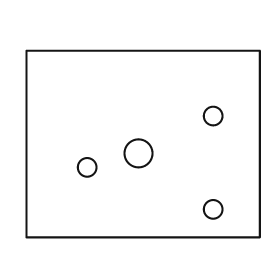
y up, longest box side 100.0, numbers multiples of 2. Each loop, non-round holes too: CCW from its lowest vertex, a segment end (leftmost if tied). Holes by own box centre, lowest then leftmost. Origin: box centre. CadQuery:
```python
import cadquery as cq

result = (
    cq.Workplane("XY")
    .moveTo(-50.0, -40.0)
    .lineTo(50.0, -40.0)
    .lineTo(50.0, 40.0)
    .lineTo(-50.0, 40.0)
    .close()
    .moveTo(30.0, -28.0)
    .circle(4.0)
    .moveTo(-24.0, -10.0)
    .circle(4.0)
    .moveTo(-2.0, -4.0)
    .circle(6.0)
    .moveTo(30.0, 12.0)
    .circle(4.0)
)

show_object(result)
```